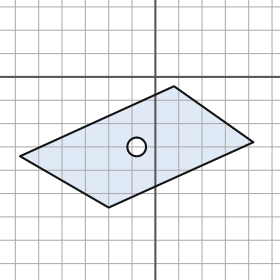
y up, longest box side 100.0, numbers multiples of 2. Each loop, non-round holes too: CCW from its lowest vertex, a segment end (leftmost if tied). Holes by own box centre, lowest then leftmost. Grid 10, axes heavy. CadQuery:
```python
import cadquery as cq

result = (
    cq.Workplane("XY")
    .moveTo(-20.0, -56.0)
    .lineTo(42.0, -28.0)
    .lineTo(8.0, -4.0)
    .lineTo(-58.0, -34.0)
    .close()
    .moveTo(-8.0, -30.0)
    .circle(4.0)
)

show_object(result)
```